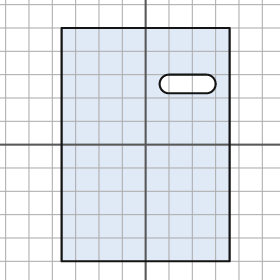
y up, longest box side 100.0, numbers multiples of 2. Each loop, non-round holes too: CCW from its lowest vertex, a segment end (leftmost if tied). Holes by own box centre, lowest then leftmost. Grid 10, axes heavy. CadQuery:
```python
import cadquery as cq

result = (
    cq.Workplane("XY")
    .moveTo(-36.0, -50.0)
    .lineTo(36.0, -50.0)
    .lineTo(36.0, 50.0)
    .lineTo(-36.0, 50.0)
    .close()
    .moveTo(10.0, 22.0)
    .lineTo(26.0, 22.0)
    .threePointArc((30.0, 26.0), (26.0, 30.0))
    .lineTo(10.0, 30.0)
    .threePointArc((6.0, 26.0), (10.0, 22.0))
    .close()
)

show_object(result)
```